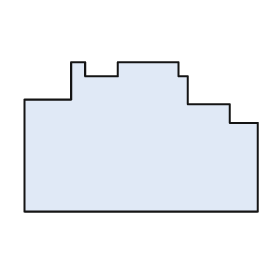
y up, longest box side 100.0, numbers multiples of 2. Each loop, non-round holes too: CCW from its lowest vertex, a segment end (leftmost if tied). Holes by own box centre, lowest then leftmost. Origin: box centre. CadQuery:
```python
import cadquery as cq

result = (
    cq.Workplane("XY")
    .moveTo(-50.0, -32.0)
    .lineTo(50.0, -32.0)
    .lineTo(50.0, 6.0)
    .lineTo(38.0, 6.0)
    .lineTo(38.0, 14.0)
    .lineTo(20.0, 14.0)
    .lineTo(20.0, 26.0)
    .lineTo(16.0, 26.0)
    .lineTo(16.0, 32.0)
    .lineTo(-10.0, 32.0)
    .lineTo(-10.0, 26.0)
    .lineTo(-24.0, 26.0)
    .lineTo(-24.0, 32.0)
    .lineTo(-30.0, 32.0)
    .lineTo(-30.0, 16.0)
    .lineTo(-50.0, 16.0)
    .close()
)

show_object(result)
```